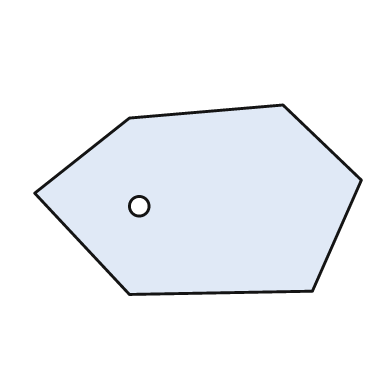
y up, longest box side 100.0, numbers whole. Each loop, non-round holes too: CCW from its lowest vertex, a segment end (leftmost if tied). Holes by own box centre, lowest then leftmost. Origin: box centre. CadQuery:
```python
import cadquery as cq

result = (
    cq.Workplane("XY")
    .moveTo(-21.0, -29.0)
    .lineTo(35.0, -28.0)
    .lineTo(50.0, 6.0)
    .lineTo(26.0, 29.0)
    .lineTo(-21.0, 25.0)
    .lineTo(-50.0, 2.0)
    .close()
    .moveTo(-18.0, -2.0)
    .circle(3.0)
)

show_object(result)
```